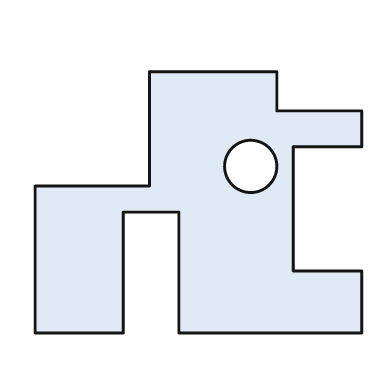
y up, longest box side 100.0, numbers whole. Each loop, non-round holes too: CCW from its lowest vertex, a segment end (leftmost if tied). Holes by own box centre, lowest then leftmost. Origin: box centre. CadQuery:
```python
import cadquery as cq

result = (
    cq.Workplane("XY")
    .moveTo(-50.0, -40.0)
    .lineTo(-23.0, -40.0)
    .lineTo(-23.0, -3.0)
    .lineTo(-6.0, -3.0)
    .lineTo(-6.0, -40.0)
    .lineTo(50.0, -40.0)
    .lineTo(50.0, -21.0)
    .lineTo(29.0, -21.0)
    .lineTo(29.0, 17.0)
    .lineTo(50.0, 17.0)
    .lineTo(50.0, 28.0)
    .lineTo(24.0, 28.0)
    .lineTo(24.0, 40.0)
    .lineTo(-15.0, 40.0)
    .lineTo(-15.0, 5.0)
    .lineTo(-50.0, 5.0)
    .close()
    .moveTo(16.0, 11.0)
    .circle(8.0)
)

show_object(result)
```